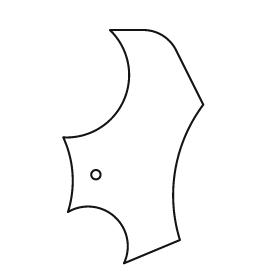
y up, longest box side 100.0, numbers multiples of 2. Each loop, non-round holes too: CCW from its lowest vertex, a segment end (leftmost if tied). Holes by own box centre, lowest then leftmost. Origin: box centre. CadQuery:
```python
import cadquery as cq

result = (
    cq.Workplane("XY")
    .moveTo(-4.0, -50.0)
    .lineTo(20.0, -40.0)
    .threePointArc((18.0, -10.0), (30.0, 18.0))
    .lineTo(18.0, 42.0)
    .threePointArc((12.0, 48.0), (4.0, 50.0))
    .lineTo(-10.0, 50.0)
    .threePointArc((-4.0, 20.0), (-30.0, 4.0))
    .threePointArc((-26.0, -12.0), (-28.0, -28.0))
    .threePointArc((-8.0, -30.0), (-4.0, -50.0))
    .close()
    .moveTo(-16.0, -12.0)
    .circle(2.0)
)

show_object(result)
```